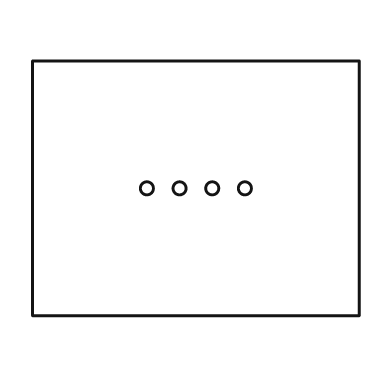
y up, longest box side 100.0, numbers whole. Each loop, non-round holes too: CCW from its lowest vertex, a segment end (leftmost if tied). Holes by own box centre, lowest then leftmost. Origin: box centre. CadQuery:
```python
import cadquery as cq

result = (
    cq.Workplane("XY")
    .moveTo(-50.0, -39.0)
    .lineTo(50.0, -39.0)
    .lineTo(50.0, 39.0)
    .lineTo(-50.0, 39.0)
    .close()
    .moveTo(-15.0, 0.0)
    .circle(2.0)
    .moveTo(-5.0, 0.0)
    .circle(2.0)
    .moveTo(5.0, 0.0)
    .circle(2.0)
    .moveTo(15.0, 0.0)
    .circle(2.0)
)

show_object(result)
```